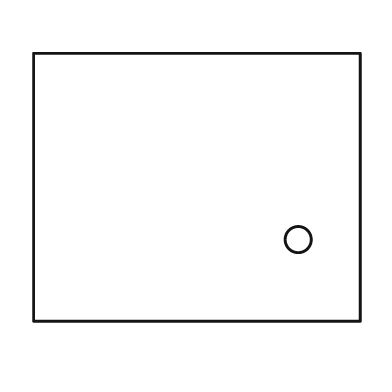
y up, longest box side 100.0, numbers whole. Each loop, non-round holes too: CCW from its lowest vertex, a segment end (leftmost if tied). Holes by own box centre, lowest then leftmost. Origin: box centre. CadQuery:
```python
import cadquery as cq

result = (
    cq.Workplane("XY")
    .moveTo(-50.0, -41.0)
    .lineTo(50.0, -41.0)
    .lineTo(50.0, 41.0)
    .lineTo(-50.0, 41.0)
    .close()
    .moveTo(31.0, -16.0)
    .circle(4.0)
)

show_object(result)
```